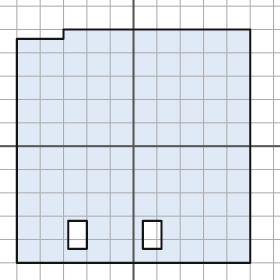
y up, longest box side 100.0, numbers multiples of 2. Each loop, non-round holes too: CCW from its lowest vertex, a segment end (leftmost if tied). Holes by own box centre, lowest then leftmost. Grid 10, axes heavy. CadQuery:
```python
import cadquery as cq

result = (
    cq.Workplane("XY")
    .moveTo(-50.0, -50.0)
    .lineTo(50.0, -50.0)
    .lineTo(50.0, 50.0)
    .lineTo(-30.0, 50.0)
    .lineTo(-30.0, 46.0)
    .lineTo(-50.0, 46.0)
    .close()
    .moveTo(-28.0, -44.0)
    .lineTo(-20.0, -44.0)
    .lineTo(-20.0, -32.0)
    .lineTo(-28.0, -32.0)
    .close()
    .moveTo(4.0, -44.0)
    .lineTo(12.0, -44.0)
    .lineTo(12.0, -32.0)
    .lineTo(4.0, -32.0)
    .close()
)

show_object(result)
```